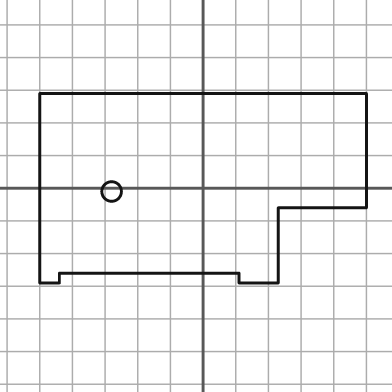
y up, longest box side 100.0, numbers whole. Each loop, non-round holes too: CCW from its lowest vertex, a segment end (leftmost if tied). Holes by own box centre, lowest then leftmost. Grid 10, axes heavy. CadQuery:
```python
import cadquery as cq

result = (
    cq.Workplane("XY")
    .moveTo(-50.0, -29.0)
    .lineTo(-44.0, -29.0)
    .lineTo(-44.0, -26.0)
    .lineTo(11.0, -26.0)
    .lineTo(11.0, -29.0)
    .lineTo(23.0, -29.0)
    .lineTo(23.0, -6.0)
    .lineTo(50.0, -6.0)
    .lineTo(50.0, 29.0)
    .lineTo(-50.0, 29.0)
    .close()
    .moveTo(-28.0, -1.0)
    .circle(3.0)
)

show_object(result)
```